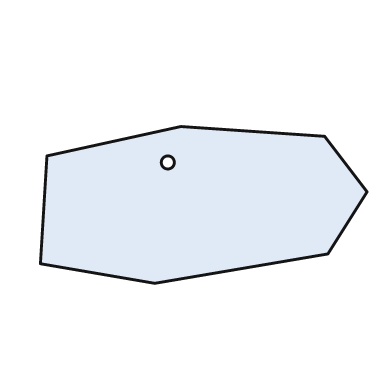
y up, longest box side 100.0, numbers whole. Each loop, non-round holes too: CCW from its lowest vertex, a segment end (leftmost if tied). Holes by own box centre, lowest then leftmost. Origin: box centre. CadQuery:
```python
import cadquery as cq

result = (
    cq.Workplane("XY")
    .moveTo(-15.0, -24.0)
    .lineTo(38.0, -15.0)
    .lineTo(50.0, 4.0)
    .lineTo(37.0, 21.0)
    .lineTo(-7.0, 24.0)
    .lineTo(-48.0, 15.0)
    .lineTo(-50.0, -18.0)
    .close()
    .moveTo(-11.0, 13.0)
    .circle(2.0)
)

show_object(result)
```